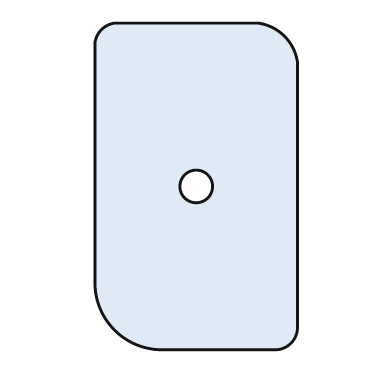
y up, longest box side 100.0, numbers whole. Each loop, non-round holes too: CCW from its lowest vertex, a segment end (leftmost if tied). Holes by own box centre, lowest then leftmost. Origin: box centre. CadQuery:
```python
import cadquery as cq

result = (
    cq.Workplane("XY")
    .moveTo(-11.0, -50.0)
    .lineTo(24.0, -50.0)
    .threePointArc((29.0, -48.0), (31.0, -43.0))
    .lineTo(31.0, 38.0)
    .threePointArc((27.0, 46.0), (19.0, 50.0))
    .lineTo(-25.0, 50.0)
    .threePointArc((-29.0, 48.0), (-31.0, 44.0))
    .lineTo(-31.0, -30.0)
    .threePointArc((-25.0, -44.0), (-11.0, -50.0))
    .close()
    .moveTo(0.0, 0.0)
    .circle(5.0)
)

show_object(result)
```